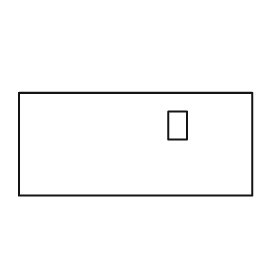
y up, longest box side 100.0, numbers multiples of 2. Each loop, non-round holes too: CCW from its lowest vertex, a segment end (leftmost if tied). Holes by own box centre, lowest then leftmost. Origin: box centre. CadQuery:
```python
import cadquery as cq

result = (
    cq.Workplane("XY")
    .moveTo(-50.0, -22.0)
    .lineTo(50.0, -22.0)
    .lineTo(50.0, 22.0)
    .lineTo(-50.0, 22.0)
    .close()
    .moveTo(14.0, 2.0)
    .lineTo(22.0, 2.0)
    .lineTo(22.0, 14.0)
    .lineTo(14.0, 14.0)
    .close()
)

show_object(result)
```